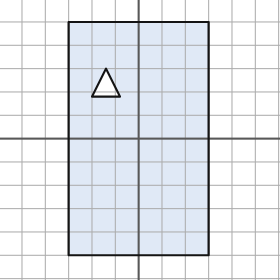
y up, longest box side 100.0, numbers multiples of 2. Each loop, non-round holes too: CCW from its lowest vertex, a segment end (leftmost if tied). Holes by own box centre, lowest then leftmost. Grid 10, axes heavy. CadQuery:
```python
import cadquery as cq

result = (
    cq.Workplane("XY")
    .moveTo(-30.0, -50.0)
    .lineTo(30.0, -50.0)
    .lineTo(30.0, 50.0)
    .lineTo(-30.0, 50.0)
    .close()
    .moveTo(-20.0, 18.0)
    .lineTo(-8.0, 18.0)
    .lineTo(-14.0, 30.0)
    .close()
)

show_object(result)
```